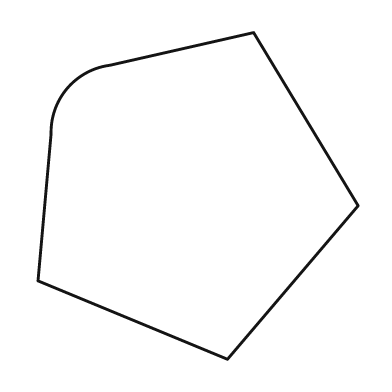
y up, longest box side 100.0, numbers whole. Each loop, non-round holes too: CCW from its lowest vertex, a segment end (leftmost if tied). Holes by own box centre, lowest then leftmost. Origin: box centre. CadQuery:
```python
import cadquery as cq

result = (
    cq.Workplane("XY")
    .moveTo(9.0, -50.0)
    .lineTo(49.0, -3.0)
    .lineTo(17.0, 50.0)
    .lineTo(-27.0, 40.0)
    .threePointArc((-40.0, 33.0), (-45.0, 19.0))
    .lineTo(-49.0, -26.0)
    .close()
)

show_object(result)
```